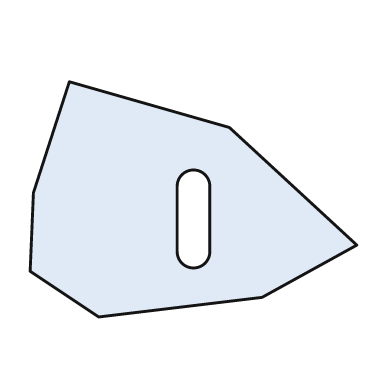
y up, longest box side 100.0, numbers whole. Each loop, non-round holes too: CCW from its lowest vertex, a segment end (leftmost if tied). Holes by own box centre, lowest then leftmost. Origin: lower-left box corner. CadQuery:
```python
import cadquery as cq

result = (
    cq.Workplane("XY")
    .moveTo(21.0, 0.0)
    .lineTo(71.0, 6.0)
    .lineTo(100.0, 22.0)
    .lineTo(61.0, 58.0)
    .lineTo(12.0, 72.0)
    .lineTo(1.0, 38.0)
    .lineTo(0.0, 14.0)
    .close()
    .moveTo(45.0, 20.0)
    .threePointArc((50.0, 15.0), (55.0, 20.0))
    .lineTo(55.0, 40.0)
    .threePointArc((50.0, 45.0), (45.0, 40.0))
    .close()
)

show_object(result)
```